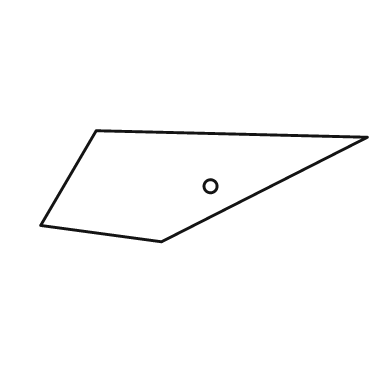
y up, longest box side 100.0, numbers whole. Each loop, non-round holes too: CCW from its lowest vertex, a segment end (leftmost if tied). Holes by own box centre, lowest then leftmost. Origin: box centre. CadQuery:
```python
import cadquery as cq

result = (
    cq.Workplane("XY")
    .moveTo(-13.0, -17.0)
    .lineTo(50.0, 15.0)
    .lineTo(-33.0, 17.0)
    .lineTo(-50.0, -12.0)
    .close()
    .moveTo(2.0, 0.0)
    .circle(2.0)
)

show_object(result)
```